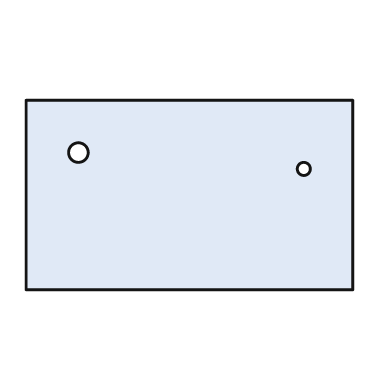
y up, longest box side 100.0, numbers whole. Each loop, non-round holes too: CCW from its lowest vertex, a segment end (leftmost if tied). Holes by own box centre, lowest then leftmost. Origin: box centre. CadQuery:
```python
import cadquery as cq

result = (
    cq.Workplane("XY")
    .moveTo(-50.0, -29.0)
    .lineTo(50.0, -29.0)
    .lineTo(50.0, 29.0)
    .lineTo(-50.0, 29.0)
    .close()
    .moveTo(35.0, 8.0)
    .circle(2.0)
    .moveTo(-34.0, 13.0)
    .circle(3.0)
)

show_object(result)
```